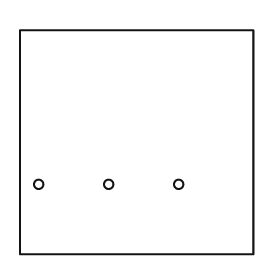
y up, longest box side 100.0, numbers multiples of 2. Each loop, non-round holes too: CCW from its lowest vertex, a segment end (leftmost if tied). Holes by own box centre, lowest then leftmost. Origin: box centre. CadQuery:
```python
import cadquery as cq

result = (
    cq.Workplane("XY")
    .moveTo(-50.0, -48.0)
    .lineTo(50.0, -48.0)
    .lineTo(50.0, 48.0)
    .lineTo(-50.0, 48.0)
    .close()
    .moveTo(-42.0, -18.0)
    .circle(2.0)
    .moveTo(-12.0, -18.0)
    .circle(2.0)
    .moveTo(18.0, -18.0)
    .circle(2.0)
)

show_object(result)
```